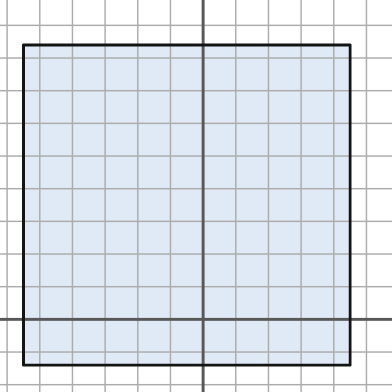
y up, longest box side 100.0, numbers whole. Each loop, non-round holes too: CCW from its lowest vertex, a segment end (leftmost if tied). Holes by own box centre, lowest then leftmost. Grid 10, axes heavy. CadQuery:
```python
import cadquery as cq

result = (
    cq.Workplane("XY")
    .moveTo(-55.0, -14.0)
    .lineTo(45.0, -14.0)
    .lineTo(45.0, 84.0)
    .lineTo(-55.0, 84.0)
    .close()
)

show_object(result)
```